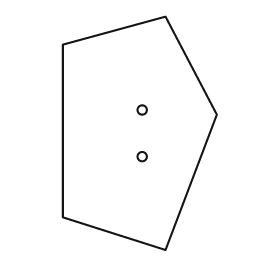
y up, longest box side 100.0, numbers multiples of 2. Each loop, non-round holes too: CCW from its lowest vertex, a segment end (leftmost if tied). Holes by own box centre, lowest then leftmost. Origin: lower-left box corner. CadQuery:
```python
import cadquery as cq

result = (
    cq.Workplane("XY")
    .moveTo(44.0, 0.0)
    .lineTo(66.0, 58.0)
    .lineTo(44.0, 100.0)
    .lineTo(0.0, 88.0)
    .lineTo(0.0, 14.0)
    .close()
    .moveTo(34.0, 40.0)
    .circle(2.0)
    .moveTo(34.0, 60.0)
    .circle(2.0)
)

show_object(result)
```